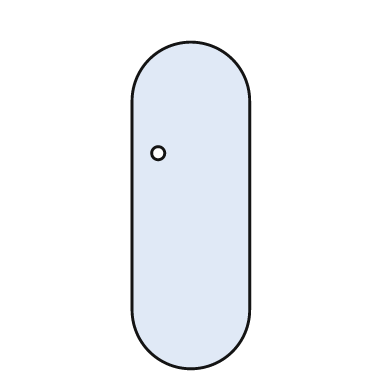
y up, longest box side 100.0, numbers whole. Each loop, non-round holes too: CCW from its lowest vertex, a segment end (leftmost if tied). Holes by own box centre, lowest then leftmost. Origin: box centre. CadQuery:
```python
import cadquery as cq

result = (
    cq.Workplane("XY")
    .moveTo(-18.0, -32.0)
    .threePointArc((0.0, -50.0), (18.0, -32.0))
    .lineTo(18.0, 32.0)
    .threePointArc((0.0, 50.0), (-18.0, 32.0))
    .close()
    .moveTo(-10.0, 16.0)
    .circle(2.0)
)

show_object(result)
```